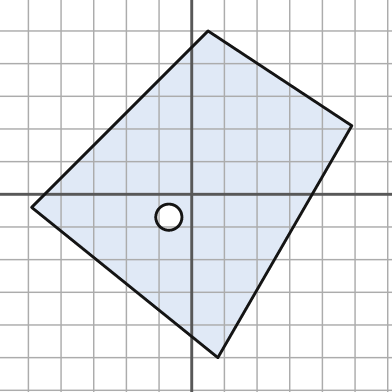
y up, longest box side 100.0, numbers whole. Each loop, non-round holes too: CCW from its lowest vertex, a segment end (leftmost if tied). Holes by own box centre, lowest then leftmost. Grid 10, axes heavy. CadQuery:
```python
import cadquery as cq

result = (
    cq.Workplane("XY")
    .moveTo(8.0, -50.0)
    .lineTo(49.0, 21.0)
    .lineTo(5.0, 50.0)
    .lineTo(-49.0, -4.0)
    .close()
    .moveTo(-7.0, -7.0)
    .circle(4.0)
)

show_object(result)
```